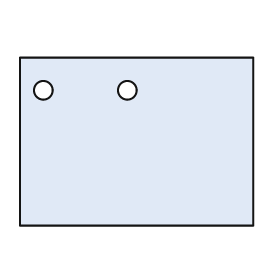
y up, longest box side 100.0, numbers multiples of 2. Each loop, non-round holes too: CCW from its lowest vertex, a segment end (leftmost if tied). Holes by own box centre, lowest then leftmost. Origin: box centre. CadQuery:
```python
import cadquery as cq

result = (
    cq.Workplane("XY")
    .moveTo(-50.0, -36.0)
    .lineTo(50.0, -36.0)
    .lineTo(50.0, 36.0)
    .lineTo(-50.0, 36.0)
    .close()
    .moveTo(-40.0, 22.0)
    .circle(4.0)
    .moveTo(-4.0, 22.0)
    .circle(4.0)
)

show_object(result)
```